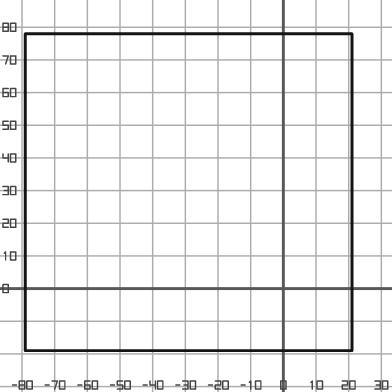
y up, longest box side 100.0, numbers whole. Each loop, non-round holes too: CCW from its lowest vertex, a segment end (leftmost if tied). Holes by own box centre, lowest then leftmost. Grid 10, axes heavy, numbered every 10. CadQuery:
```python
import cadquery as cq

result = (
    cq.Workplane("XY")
    .moveTo(-79.0, -19.0)
    .lineTo(21.0, -19.0)
    .lineTo(21.0, 78.0)
    .lineTo(-79.0, 78.0)
    .close()
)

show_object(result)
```